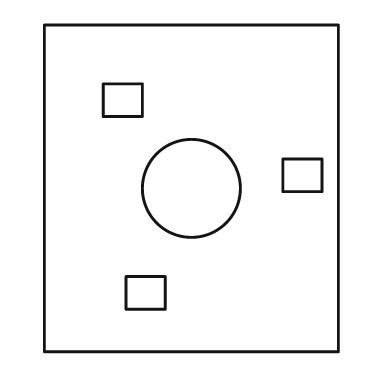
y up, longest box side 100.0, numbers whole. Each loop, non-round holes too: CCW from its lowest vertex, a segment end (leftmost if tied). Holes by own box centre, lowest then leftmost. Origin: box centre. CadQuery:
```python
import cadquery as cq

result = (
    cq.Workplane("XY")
    .moveTo(-45.0, -50.0)
    .lineTo(45.0, -50.0)
    .lineTo(45.0, 50.0)
    .lineTo(-45.0, 50.0)
    .close()
    .moveTo(-20.0, -37.0)
    .lineTo(-8.0, -37.0)
    .lineTo(-8.0, -27.0)
    .lineTo(-20.0, -27.0)
    .close()
    .moveTo(0.0, 0.0)
    .circle(15.0)
    .moveTo(28.0, -1.0)
    .lineTo(40.0, -1.0)
    .lineTo(40.0, 9.0)
    .lineTo(28.0, 9.0)
    .close()
    .moveTo(-27.0, 22.0)
    .lineTo(-15.0, 22.0)
    .lineTo(-15.0, 32.0)
    .lineTo(-27.0, 32.0)
    .close()
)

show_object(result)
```